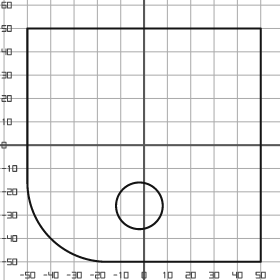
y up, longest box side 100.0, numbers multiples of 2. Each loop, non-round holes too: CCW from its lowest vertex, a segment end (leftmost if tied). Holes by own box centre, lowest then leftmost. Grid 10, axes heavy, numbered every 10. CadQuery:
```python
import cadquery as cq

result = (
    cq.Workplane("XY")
    .moveTo(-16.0, -50.0)
    .lineTo(50.0, -50.0)
    .lineTo(50.0, 50.0)
    .lineTo(-50.0, 50.0)
    .lineTo(-50.0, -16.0)
    .threePointArc((-40.0, -40.0), (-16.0, -50.0))
    .close()
    .moveTo(-2.0, -26.0)
    .circle(10.0)
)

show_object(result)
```